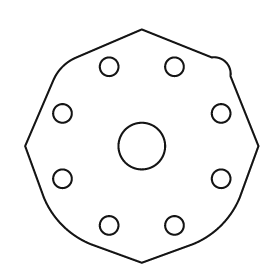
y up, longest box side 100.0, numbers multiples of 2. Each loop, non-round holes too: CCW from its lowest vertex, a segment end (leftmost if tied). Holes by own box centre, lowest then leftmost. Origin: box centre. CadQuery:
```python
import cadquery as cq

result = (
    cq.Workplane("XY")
    .moveTo(0.0, -50.0)
    .lineTo(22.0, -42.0)
    .threePointArc((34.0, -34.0), (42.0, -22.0))
    .lineTo(50.0, 0.0)
    .lineTo(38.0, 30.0)
    .threePointArc((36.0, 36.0), (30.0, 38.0))
    .lineTo(0.0, 50.0)
    .lineTo(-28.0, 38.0)
    .threePointArc((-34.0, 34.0), (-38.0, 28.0))
    .lineTo(-50.0, 0.0)
    .lineTo(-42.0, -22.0)
    .threePointArc((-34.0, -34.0), (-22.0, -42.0))
    .close()
    .moveTo(-14.0, -34.0)
    .circle(4.0)
    .moveTo(14.0, -34.0)
    .circle(4.0)
    .moveTo(-34.0, -14.0)
    .circle(4.0)
    .moveTo(34.0, -14.0)
    .circle(4.0)
    .moveTo(0.0, 0.0)
    .circle(10.0)
    .moveTo(-34.0, 14.0)
    .circle(4.0)
    .moveTo(34.0, 14.0)
    .circle(4.0)
    .moveTo(-14.0, 34.0)
    .circle(4.0)
    .moveTo(14.0, 34.0)
    .circle(4.0)
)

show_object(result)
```